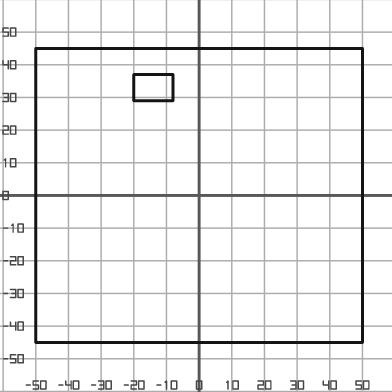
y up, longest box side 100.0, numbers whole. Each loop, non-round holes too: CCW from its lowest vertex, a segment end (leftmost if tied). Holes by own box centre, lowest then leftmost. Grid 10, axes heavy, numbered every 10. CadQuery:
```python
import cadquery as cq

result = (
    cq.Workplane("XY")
    .moveTo(-50.0, -45.0)
    .lineTo(50.0, -45.0)
    .lineTo(50.0, 45.0)
    .lineTo(-50.0, 45.0)
    .close()
    .moveTo(-20.0, 29.0)
    .lineTo(-8.0, 29.0)
    .lineTo(-8.0, 37.0)
    .lineTo(-20.0, 37.0)
    .close()
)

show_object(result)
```